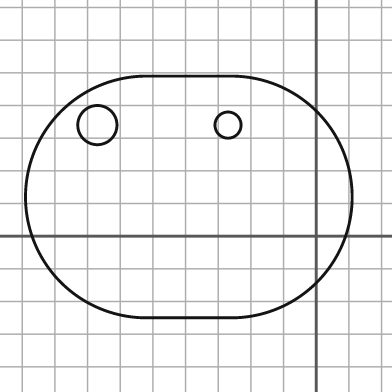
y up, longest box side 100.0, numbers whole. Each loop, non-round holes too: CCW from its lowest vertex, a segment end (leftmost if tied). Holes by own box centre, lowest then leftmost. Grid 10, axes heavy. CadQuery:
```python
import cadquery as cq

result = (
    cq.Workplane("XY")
    .moveTo(-52.0, -25.0)
    .lineTo(-26.0, -25.0)
    .threePointArc((11.0, 12.0), (-26.0, 49.0))
    .lineTo(-52.0, 49.0)
    .threePointArc((-89.0, 12.0), (-52.0, -25.0))
    .close()
    .moveTo(-67.0, 34.0)
    .circle(6.0)
    .moveTo(-27.0, 34.0)
    .circle(4.0)
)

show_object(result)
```